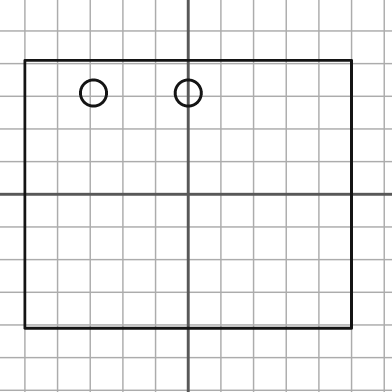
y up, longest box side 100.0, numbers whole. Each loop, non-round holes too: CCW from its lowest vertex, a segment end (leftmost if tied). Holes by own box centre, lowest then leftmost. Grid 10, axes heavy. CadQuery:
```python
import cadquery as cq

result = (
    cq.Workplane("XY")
    .moveTo(-50.0, -41.0)
    .lineTo(50.0, -41.0)
    .lineTo(50.0, 41.0)
    .lineTo(-50.0, 41.0)
    .close()
    .moveTo(-29.0, 31.0)
    .circle(4.0)
    .moveTo(0.0, 31.0)
    .circle(4.0)
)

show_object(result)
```